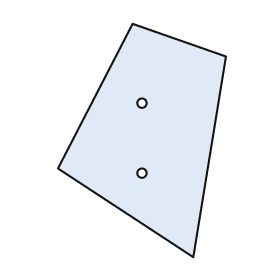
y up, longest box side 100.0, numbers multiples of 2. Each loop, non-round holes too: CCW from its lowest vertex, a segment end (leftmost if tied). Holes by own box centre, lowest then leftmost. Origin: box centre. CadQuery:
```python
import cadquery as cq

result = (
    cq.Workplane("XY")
    .moveTo(22.0, -50.0)
    .lineTo(36.0, 36.0)
    .lineTo(-4.0, 50.0)
    .lineTo(-36.0, -12.0)
    .close()
    .moveTo(0.0, -14.0)
    .circle(2.0)
    .moveTo(0.0, 16.0)
    .circle(2.0)
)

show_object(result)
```